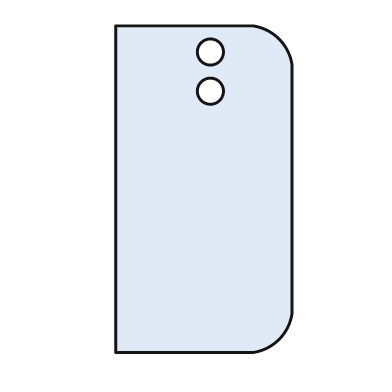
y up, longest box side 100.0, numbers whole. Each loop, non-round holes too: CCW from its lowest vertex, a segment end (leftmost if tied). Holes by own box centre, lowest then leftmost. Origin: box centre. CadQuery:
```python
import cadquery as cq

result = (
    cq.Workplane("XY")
    .moveTo(-27.0, -50.0)
    .lineTo(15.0, -50.0)
    .threePointArc((23.0, -46.0), (27.0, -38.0))
    .lineTo(27.0, 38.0)
    .threePointArc((23.0, 46.0), (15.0, 50.0))
    .lineTo(-27.0, 50.0)
    .close()
    .moveTo(2.0, 30.0)
    .circle(4.0)
    .moveTo(2.0, 42.0)
    .circle(4.0)
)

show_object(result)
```